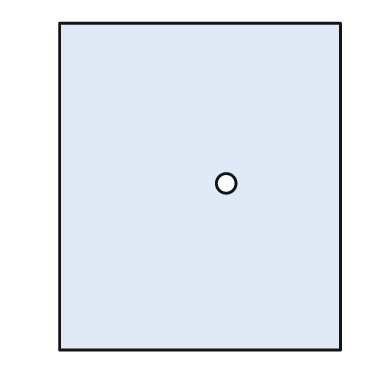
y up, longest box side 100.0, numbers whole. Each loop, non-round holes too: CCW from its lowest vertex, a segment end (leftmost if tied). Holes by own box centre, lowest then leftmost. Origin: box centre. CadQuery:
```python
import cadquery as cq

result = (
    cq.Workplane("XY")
    .moveTo(-43.0, -50.0)
    .lineTo(43.0, -50.0)
    .lineTo(43.0, 50.0)
    .lineTo(-43.0, 50.0)
    .close()
    .moveTo(8.0, 1.0)
    .circle(3.0)
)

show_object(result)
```